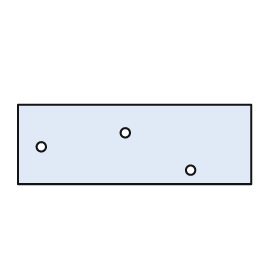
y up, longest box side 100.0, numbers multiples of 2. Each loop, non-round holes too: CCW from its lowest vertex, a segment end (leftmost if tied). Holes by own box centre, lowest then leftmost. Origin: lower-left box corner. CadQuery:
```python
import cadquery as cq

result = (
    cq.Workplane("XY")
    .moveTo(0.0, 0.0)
    .lineTo(100.0, 0.0)
    .lineTo(100.0, 34.0)
    .lineTo(0.0, 34.0)
    .close()
    .moveTo(74.0, 6.0)
    .circle(2.0)
    .moveTo(10.0, 16.0)
    .circle(2.0)
    .moveTo(46.0, 22.0)
    .circle(2.0)
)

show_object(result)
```